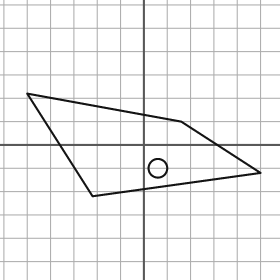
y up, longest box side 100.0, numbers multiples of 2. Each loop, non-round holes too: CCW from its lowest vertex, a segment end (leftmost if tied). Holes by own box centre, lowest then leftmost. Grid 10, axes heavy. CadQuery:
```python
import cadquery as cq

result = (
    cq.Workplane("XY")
    .moveTo(-22.0, -22.0)
    .lineTo(50.0, -12.0)
    .lineTo(16.0, 10.0)
    .lineTo(-50.0, 22.0)
    .close()
    .moveTo(6.0, -10.0)
    .circle(4.0)
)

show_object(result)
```